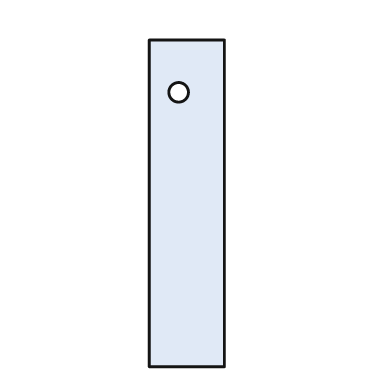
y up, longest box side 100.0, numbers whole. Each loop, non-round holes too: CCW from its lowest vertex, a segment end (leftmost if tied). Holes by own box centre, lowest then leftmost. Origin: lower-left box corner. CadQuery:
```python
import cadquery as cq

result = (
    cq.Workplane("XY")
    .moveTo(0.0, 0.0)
    .lineTo(23.0, 0.0)
    .lineTo(23.0, 100.0)
    .lineTo(0.0, 100.0)
    .close()
    .moveTo(9.0, 84.0)
    .circle(3.0)
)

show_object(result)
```